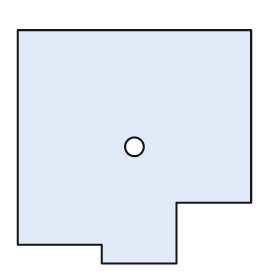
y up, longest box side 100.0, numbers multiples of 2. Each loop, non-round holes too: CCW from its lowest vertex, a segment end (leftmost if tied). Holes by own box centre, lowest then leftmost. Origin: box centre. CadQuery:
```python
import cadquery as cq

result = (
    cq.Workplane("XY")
    .moveTo(-14.0, -50.0)
    .lineTo(18.0, -50.0)
    .lineTo(18.0, -24.0)
    .lineTo(50.0, -24.0)
    .lineTo(50.0, 50.0)
    .lineTo(-50.0, 50.0)
    .lineTo(-50.0, -42.0)
    .lineTo(-14.0, -42.0)
    .close()
    .moveTo(0.0, 0.0)
    .circle(4.0)
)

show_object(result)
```